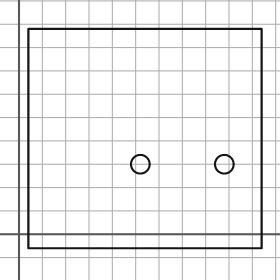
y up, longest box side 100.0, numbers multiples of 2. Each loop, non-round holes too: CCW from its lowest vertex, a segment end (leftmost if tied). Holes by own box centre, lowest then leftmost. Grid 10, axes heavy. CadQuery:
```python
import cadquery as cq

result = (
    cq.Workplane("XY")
    .moveTo(4.0, -6.0)
    .lineTo(104.0, -6.0)
    .lineTo(104.0, 88.0)
    .lineTo(4.0, 88.0)
    .close()
    .moveTo(52.0, 30.0)
    .circle(4.0)
    .moveTo(88.0, 30.0)
    .circle(4.0)
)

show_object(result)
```